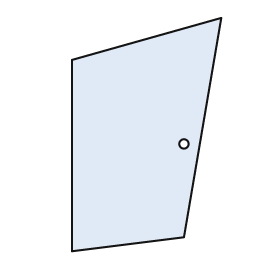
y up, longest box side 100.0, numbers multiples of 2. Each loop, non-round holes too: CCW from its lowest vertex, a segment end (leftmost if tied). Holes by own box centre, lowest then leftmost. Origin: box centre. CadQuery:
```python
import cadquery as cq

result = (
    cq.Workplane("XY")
    .moveTo(-32.0, -50.0)
    .lineTo(16.0, -44.0)
    .lineTo(32.0, 50.0)
    .lineTo(-32.0, 32.0)
    .close()
    .moveTo(16.0, -4.0)
    .circle(2.0)
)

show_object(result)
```